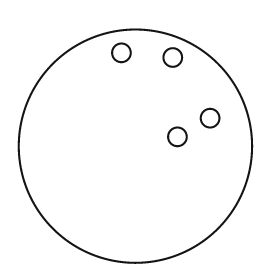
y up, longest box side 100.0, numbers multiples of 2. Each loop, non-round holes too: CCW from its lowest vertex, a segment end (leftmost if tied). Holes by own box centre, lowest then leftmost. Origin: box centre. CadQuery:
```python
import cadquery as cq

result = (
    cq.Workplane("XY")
    .moveTo(0.0, 0.0)
    .circle(50.0)
    .moveTo(18.0, 4.0)
    .circle(4.0)
    .moveTo(32.0, 12.0)
    .circle(4.0)
    .moveTo(16.0, 38.0)
    .circle(4.0)
    .moveTo(-6.0, 40.0)
    .circle(4.0)
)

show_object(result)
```